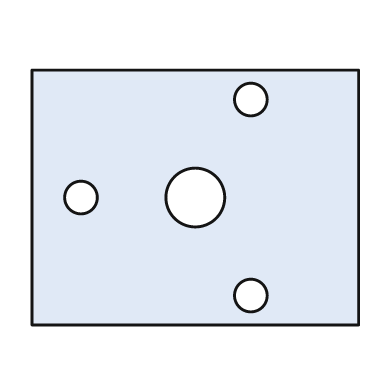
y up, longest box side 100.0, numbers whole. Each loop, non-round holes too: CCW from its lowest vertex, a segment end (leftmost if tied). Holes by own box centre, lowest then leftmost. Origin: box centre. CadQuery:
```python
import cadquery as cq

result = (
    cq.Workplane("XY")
    .moveTo(-50.0, -39.0)
    .lineTo(50.0, -39.0)
    .lineTo(50.0, 39.0)
    .lineTo(-50.0, 39.0)
    .close()
    .moveTo(17.0, -30.0)
    .circle(5.0)
    .moveTo(-35.0, 0.0)
    .circle(5.0)
    .moveTo(0.0, 0.0)
    .circle(9.0)
    .moveTo(17.0, 30.0)
    .circle(5.0)
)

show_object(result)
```